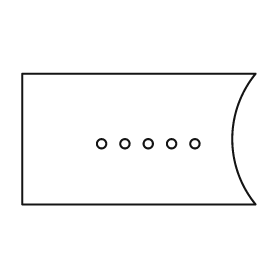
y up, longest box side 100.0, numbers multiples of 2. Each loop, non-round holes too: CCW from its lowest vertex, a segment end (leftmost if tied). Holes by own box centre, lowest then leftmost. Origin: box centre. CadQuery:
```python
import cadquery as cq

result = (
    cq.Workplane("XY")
    .moveTo(-50.0, -28.0)
    .lineTo(50.0, -28.0)
    .threePointArc((40.0, 0.0), (50.0, 28.0))
    .lineTo(-50.0, 28.0)
    .close()
    .moveTo(-16.0, -2.0)
    .circle(2.0)
    .moveTo(-6.0, -2.0)
    .circle(2.0)
    .moveTo(4.0, -2.0)
    .circle(2.0)
    .moveTo(14.0, -2.0)
    .circle(2.0)
    .moveTo(24.0, -2.0)
    .circle(2.0)
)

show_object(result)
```